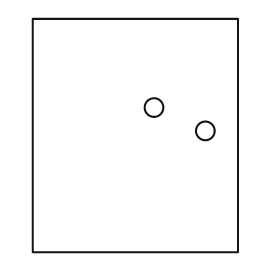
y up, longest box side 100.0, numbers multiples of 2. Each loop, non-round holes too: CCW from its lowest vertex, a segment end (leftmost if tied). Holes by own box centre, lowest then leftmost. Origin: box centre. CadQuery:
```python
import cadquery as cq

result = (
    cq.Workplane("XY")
    .moveTo(-44.0, -50.0)
    .lineTo(44.0, -50.0)
    .lineTo(44.0, 50.0)
    .lineTo(-44.0, 50.0)
    .close()
    .moveTo(30.0, 2.0)
    .circle(4.0)
    .moveTo(8.0, 12.0)
    .circle(4.0)
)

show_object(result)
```